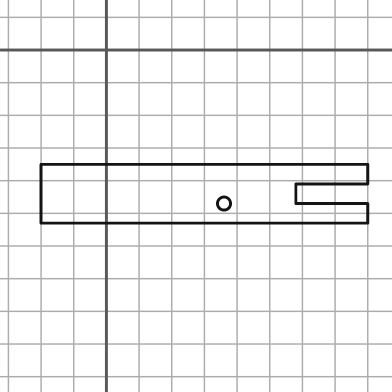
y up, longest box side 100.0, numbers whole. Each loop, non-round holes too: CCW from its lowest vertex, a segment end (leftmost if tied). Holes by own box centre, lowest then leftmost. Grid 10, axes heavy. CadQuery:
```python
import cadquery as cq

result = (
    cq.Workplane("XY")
    .moveTo(-20.0, -53.0)
    .lineTo(80.0, -53.0)
    .lineTo(80.0, -47.0)
    .lineTo(58.0, -47.0)
    .lineTo(58.0, -41.0)
    .lineTo(80.0, -41.0)
    .lineTo(80.0, -35.0)
    .lineTo(-20.0, -35.0)
    .close()
    .moveTo(36.0, -47.0)
    .circle(2.0)
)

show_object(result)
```